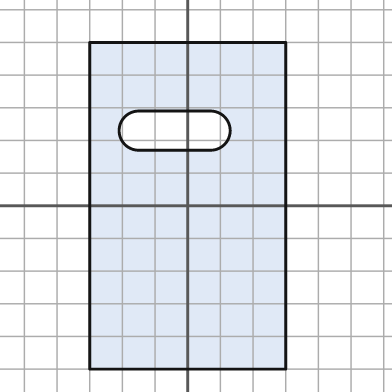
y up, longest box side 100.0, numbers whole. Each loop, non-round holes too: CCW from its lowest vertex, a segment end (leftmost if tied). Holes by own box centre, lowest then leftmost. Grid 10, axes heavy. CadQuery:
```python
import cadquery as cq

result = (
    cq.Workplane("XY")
    .moveTo(-30.0, -50.0)
    .lineTo(30.0, -50.0)
    .lineTo(30.0, 50.0)
    .lineTo(-30.0, 50.0)
    .close()
    .moveTo(-15.0, 17.0)
    .lineTo(7.0, 17.0)
    .threePointArc((13.0, 23.0), (7.0, 29.0))
    .lineTo(-15.0, 29.0)
    .threePointArc((-21.0, 23.0), (-15.0, 17.0))
    .close()
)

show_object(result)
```